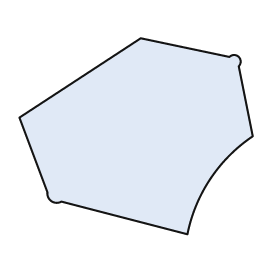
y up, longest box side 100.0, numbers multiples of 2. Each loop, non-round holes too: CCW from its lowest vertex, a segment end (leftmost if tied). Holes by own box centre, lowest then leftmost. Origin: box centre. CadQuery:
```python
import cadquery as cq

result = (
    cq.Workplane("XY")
    .moveTo(22.0, -42.0)
    .threePointArc((32.0, -18.0), (50.0, 0.0))
    .lineTo(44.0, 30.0)
    .threePointArc((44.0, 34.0), (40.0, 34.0))
    .lineTo(2.0, 42.0)
    .lineTo(-50.0, 8.0)
    .lineTo(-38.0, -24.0)
    .threePointArc((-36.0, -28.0), (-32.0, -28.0))
    .close()
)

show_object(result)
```